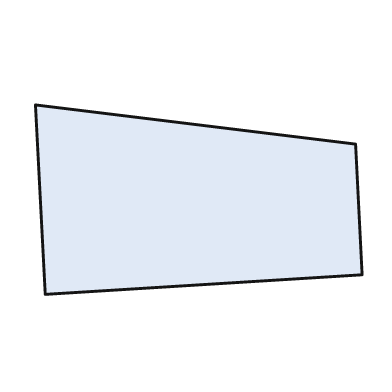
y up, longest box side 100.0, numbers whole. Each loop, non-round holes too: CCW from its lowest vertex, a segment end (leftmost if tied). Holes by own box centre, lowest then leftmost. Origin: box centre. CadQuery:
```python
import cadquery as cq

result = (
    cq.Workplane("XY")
    .moveTo(-47.0, -29.0)
    .lineTo(50.0, -23.0)
    .lineTo(48.0, 17.0)
    .lineTo(-50.0, 29.0)
    .close()
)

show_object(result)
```